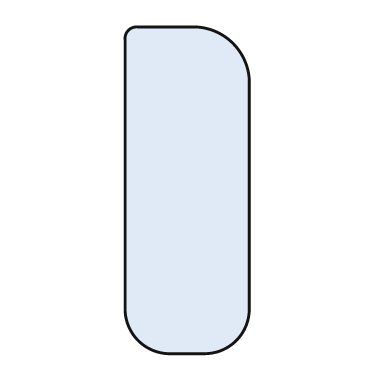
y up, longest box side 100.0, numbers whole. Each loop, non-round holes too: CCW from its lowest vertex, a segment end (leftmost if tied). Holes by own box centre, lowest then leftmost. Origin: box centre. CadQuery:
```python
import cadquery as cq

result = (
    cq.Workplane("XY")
    .moveTo(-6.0, -50.0)
    .lineTo(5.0, -50.0)
    .threePointArc((15.0, -46.0), (19.0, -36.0))
    .lineTo(19.0, 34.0)
    .threePointArc((14.0, 45.0), (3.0, 50.0))
    .lineTo(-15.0, 50.0)
    .threePointArc((-18.0, 49.0), (-19.0, 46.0))
    .lineTo(-19.0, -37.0)
    .threePointArc((-15.0, -46.0), (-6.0, -50.0))
    .close()
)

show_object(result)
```